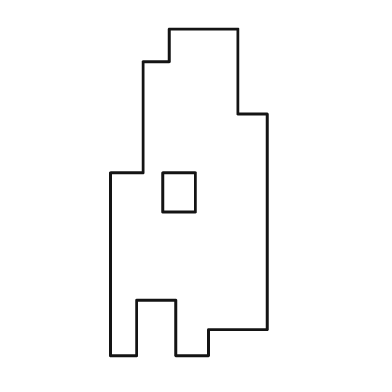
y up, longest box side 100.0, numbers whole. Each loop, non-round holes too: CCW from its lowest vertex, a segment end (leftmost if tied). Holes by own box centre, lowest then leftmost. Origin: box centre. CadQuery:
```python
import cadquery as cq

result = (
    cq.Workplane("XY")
    .moveTo(-24.0, -50.0)
    .lineTo(-16.0, -50.0)
    .lineTo(-16.0, -33.0)
    .lineTo(-4.0, -33.0)
    .lineTo(-4.0, -50.0)
    .lineTo(6.0, -50.0)
    .lineTo(6.0, -42.0)
    .lineTo(24.0, -42.0)
    .lineTo(24.0, 24.0)
    .lineTo(15.0, 24.0)
    .lineTo(15.0, 50.0)
    .lineTo(-6.0, 50.0)
    .lineTo(-6.0, 40.0)
    .lineTo(-14.0, 40.0)
    .lineTo(-14.0, 6.0)
    .lineTo(-24.0, 6.0)
    .close()
    .moveTo(-8.0, -6.0)
    .lineTo(2.0, -6.0)
    .lineTo(2.0, 6.0)
    .lineTo(-8.0, 6.0)
    .close()
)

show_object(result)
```